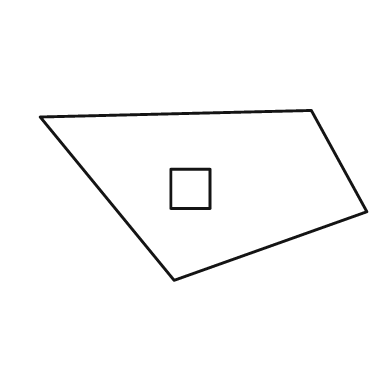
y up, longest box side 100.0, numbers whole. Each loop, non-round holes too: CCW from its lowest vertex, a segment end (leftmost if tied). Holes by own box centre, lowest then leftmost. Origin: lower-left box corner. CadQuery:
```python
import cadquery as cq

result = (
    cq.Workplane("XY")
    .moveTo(41.0, 0.0)
    .lineTo(100.0, 21.0)
    .lineTo(83.0, 52.0)
    .lineTo(0.0, 50.0)
    .close()
    .moveTo(40.0, 22.0)
    .lineTo(52.0, 22.0)
    .lineTo(52.0, 34.0)
    .lineTo(40.0, 34.0)
    .close()
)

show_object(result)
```